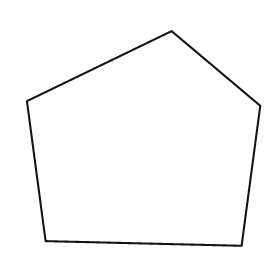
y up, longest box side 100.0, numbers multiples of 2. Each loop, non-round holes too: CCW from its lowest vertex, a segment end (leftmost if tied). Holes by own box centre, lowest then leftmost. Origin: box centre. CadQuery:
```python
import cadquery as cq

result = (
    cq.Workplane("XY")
    .moveTo(42.0, -46.0)
    .lineTo(50.0, 14.0)
    .lineTo(12.0, 46.0)
    .lineTo(-50.0, 16.0)
    .lineTo(-42.0, -44.0)
    .close()
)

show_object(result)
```